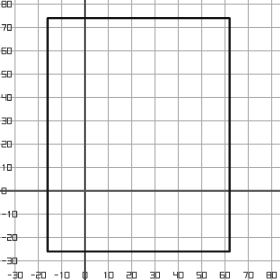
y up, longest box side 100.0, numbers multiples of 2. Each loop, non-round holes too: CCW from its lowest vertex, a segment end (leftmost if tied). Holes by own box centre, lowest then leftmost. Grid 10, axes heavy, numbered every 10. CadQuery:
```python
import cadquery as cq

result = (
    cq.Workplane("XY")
    .moveTo(-16.0, -26.0)
    .lineTo(62.0, -26.0)
    .lineTo(62.0, 74.0)
    .lineTo(-16.0, 74.0)
    .close()
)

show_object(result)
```